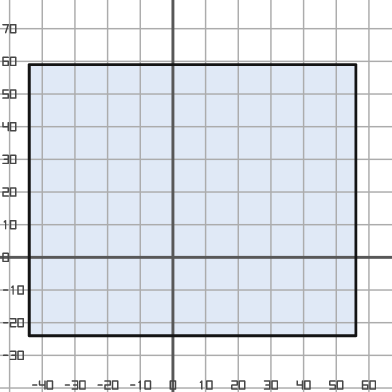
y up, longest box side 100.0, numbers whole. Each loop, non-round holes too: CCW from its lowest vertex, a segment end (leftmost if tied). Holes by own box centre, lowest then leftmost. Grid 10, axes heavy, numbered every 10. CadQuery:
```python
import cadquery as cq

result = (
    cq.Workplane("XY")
    .moveTo(-44.0, -24.0)
    .lineTo(56.0, -24.0)
    .lineTo(56.0, 59.0)
    .lineTo(-44.0, 59.0)
    .close()
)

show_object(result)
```